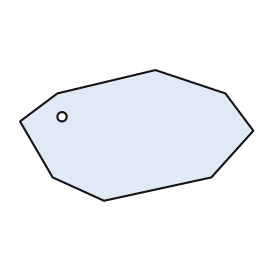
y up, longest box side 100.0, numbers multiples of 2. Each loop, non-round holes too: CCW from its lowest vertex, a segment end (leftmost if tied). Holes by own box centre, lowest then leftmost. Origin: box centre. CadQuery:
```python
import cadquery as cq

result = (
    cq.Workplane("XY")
    .moveTo(-14.0, -28.0)
    .lineTo(32.0, -18.0)
    .lineTo(50.0, 2.0)
    .lineTo(38.0, 18.0)
    .lineTo(8.0, 28.0)
    .lineTo(-34.0, 18.0)
    .lineTo(-50.0, 6.0)
    .lineTo(-36.0, -18.0)
    .close()
    .moveTo(-32.0, 8.0)
    .circle(2.0)
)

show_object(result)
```